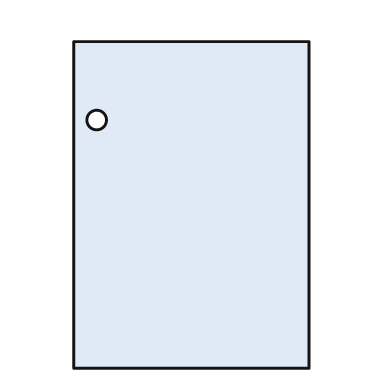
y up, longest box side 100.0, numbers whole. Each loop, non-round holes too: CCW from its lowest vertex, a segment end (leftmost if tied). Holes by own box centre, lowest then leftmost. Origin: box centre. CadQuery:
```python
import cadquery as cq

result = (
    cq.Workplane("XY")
    .moveTo(-36.0, -50.0)
    .lineTo(36.0, -50.0)
    .lineTo(36.0, 50.0)
    .lineTo(-36.0, 50.0)
    .close()
    .moveTo(-29.0, 26.0)
    .circle(3.0)
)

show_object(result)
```